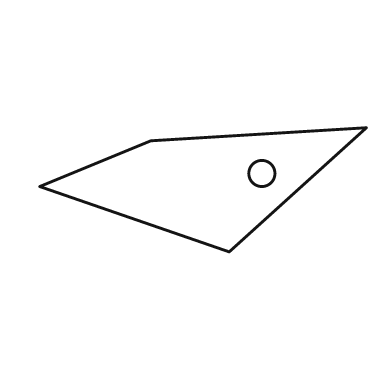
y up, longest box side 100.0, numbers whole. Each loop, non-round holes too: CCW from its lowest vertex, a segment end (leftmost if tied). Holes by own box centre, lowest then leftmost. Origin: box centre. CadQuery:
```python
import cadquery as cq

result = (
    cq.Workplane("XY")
    .moveTo(8.0, -19.0)
    .lineTo(50.0, 19.0)
    .lineTo(-16.0, 15.0)
    .lineTo(-50.0, 1.0)
    .close()
    .moveTo(18.0, 5.0)
    .circle(4.0)
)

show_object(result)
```